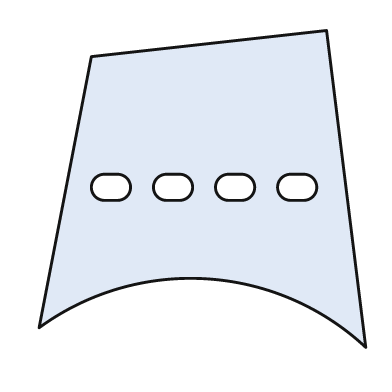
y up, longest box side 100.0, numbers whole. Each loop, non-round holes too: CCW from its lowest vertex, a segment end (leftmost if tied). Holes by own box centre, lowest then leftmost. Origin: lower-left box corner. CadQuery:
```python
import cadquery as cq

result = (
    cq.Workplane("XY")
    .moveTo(100.0, 0.0)
    .lineTo(88.0, 97.0)
    .lineTo(16.0, 89.0)
    .lineTo(0.0, 6.0)
    .threePointArc((51.0, 21.0), (100.0, 0.0))
    .close()
    .moveTo(20.0, 45.0)
    .lineTo(24.0, 45.0)
    .threePointArc((28.0, 49.0), (24.0, 53.0))
    .lineTo(20.0, 53.0)
    .threePointArc((16.0, 49.0), (20.0, 45.0))
    .close()
    .moveTo(39.0, 45.0)
    .lineTo(43.0, 45.0)
    .threePointArc((47.0, 49.0), (43.0, 53.0))
    .lineTo(39.0, 53.0)
    .threePointArc((35.0, 49.0), (39.0, 45.0))
    .close()
    .moveTo(58.0, 45.0)
    .lineTo(62.0, 45.0)
    .threePointArc((66.0, 49.0), (62.0, 53.0))
    .lineTo(58.0, 53.0)
    .threePointArc((54.0, 49.0), (58.0, 45.0))
    .close()
    .moveTo(77.0, 45.0)
    .lineTo(81.0, 45.0)
    .threePointArc((85.0, 49.0), (81.0, 53.0))
    .lineTo(77.0, 53.0)
    .threePointArc((73.0, 49.0), (77.0, 45.0))
    .close()
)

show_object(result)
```